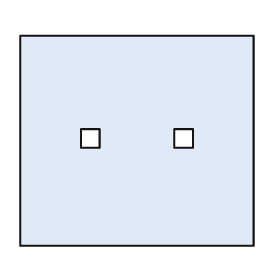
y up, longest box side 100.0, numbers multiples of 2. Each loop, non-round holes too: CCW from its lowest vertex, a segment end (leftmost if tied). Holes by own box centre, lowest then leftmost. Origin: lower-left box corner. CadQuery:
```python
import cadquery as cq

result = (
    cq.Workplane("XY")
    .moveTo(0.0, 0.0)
    .lineTo(100.0, 0.0)
    .lineTo(100.0, 90.0)
    .lineTo(0.0, 90.0)
    .close()
    .moveTo(26.0, 42.0)
    .lineTo(34.0, 42.0)
    .lineTo(34.0, 50.0)
    .lineTo(26.0, 50.0)
    .close()
    .moveTo(66.0, 42.0)
    .lineTo(74.0, 42.0)
    .lineTo(74.0, 50.0)
    .lineTo(66.0, 50.0)
    .close()
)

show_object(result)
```